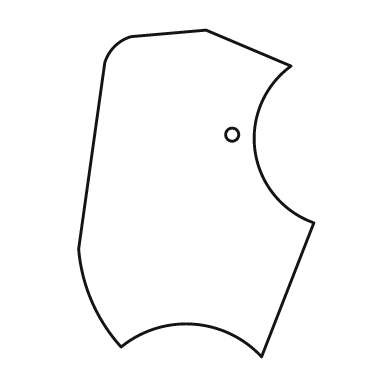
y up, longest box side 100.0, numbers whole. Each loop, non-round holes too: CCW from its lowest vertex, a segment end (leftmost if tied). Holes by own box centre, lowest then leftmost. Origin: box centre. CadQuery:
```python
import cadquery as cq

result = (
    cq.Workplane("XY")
    .moveTo(20.0, -50.0)
    .lineTo(36.0, -9.0)
    .threePointArc((18.0, 13.0), (29.0, 39.0))
    .lineTo(3.0, 50.0)
    .lineTo(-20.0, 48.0)
    .threePointArc((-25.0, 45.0), (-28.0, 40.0))
    .lineTo(-36.0, -17.0)
    .threePointArc((-32.0, -33.0), (-23.0, -47.0))
    .threePointArc((-1.0, -40.0), (20.0, -50.0))
    .close()
    .moveTo(11.0, 18.0)
    .circle(2.0)
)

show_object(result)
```